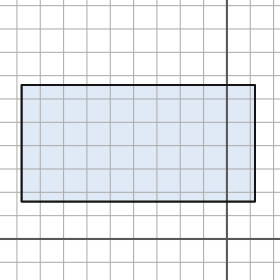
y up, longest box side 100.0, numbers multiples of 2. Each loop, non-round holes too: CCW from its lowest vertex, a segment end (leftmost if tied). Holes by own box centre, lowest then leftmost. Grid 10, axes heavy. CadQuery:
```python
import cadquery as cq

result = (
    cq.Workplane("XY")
    .moveTo(-88.0, 16.0)
    .lineTo(12.0, 16.0)
    .lineTo(12.0, 66.0)
    .lineTo(-88.0, 66.0)
    .close()
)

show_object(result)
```